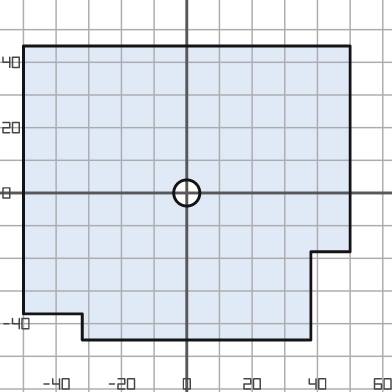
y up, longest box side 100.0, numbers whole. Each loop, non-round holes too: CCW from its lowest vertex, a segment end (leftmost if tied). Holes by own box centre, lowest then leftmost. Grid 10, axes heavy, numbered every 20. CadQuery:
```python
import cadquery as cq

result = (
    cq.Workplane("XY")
    .moveTo(-32.0, -45.0)
    .lineTo(38.0, -45.0)
    .lineTo(38.0, -18.0)
    .lineTo(50.0, -18.0)
    .lineTo(50.0, 45.0)
    .lineTo(-50.0, 45.0)
    .lineTo(-50.0, -37.0)
    .lineTo(-32.0, -37.0)
    .close()
    .moveTo(0.0, 0.0)
    .circle(4.0)
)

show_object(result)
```